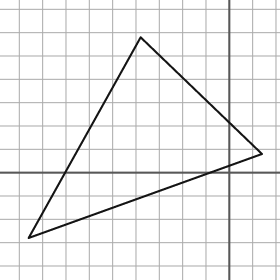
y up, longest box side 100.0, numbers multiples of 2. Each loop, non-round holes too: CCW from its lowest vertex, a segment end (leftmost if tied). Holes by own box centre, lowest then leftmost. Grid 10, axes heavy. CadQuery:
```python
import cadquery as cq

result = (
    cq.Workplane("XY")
    .moveTo(-86.0, -28.0)
    .lineTo(14.0, 8.0)
    .lineTo(-38.0, 58.0)
    .close()
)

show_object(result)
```